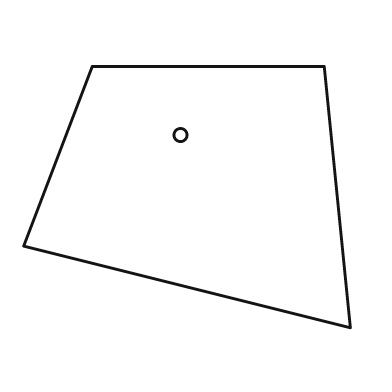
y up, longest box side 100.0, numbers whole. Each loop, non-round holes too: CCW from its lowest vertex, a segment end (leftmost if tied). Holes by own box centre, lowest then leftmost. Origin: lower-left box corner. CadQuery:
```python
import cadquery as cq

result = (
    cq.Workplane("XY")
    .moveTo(100.0, 0.0)
    .lineTo(92.0, 80.0)
    .lineTo(21.0, 80.0)
    .lineTo(0.0, 25.0)
    .close()
    .moveTo(48.0, 59.0)
    .circle(2.0)
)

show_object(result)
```